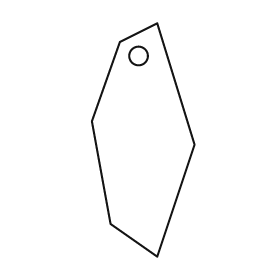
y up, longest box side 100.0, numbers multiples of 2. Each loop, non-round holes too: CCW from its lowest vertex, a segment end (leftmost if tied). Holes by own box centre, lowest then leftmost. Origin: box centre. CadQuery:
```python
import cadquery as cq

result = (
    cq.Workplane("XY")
    .moveTo(6.0, -50.0)
    .lineTo(22.0, -2.0)
    .lineTo(6.0, 50.0)
    .lineTo(-10.0, 42.0)
    .lineTo(-22.0, 8.0)
    .lineTo(-14.0, -36.0)
    .close()
    .moveTo(-2.0, 36.0)
    .circle(4.0)
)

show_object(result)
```